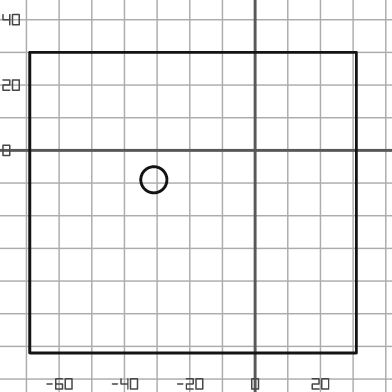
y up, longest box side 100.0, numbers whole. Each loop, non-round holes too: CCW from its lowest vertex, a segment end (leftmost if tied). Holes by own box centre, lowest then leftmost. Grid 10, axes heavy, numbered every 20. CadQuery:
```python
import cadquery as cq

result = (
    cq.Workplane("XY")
    .moveTo(-69.0, -62.0)
    .lineTo(31.0, -62.0)
    .lineTo(31.0, 30.0)
    .lineTo(-69.0, 30.0)
    .close()
    .moveTo(-31.0, -9.0)
    .circle(4.0)
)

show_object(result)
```